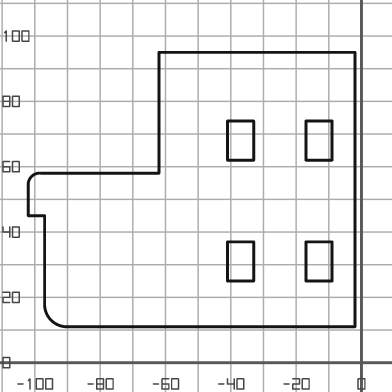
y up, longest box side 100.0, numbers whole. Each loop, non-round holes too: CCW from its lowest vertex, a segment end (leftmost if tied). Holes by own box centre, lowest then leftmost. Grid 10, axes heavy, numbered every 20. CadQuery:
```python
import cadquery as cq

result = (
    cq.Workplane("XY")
    .moveTo(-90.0, 11.0)
    .lineTo(-2.0, 11.0)
    .lineTo(-2.0, 95.0)
    .lineTo(-62.0, 95.0)
    .lineTo(-62.0, 58.0)
    .lineTo(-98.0, 58.0)
    .threePointArc((-101.0, 57.0), (-102.0, 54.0))
    .lineTo(-102.0, 45.0)
    .lineTo(-97.0, 45.0)
    .lineTo(-97.0, 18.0)
    .threePointArc((-95.0, 13.0), (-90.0, 11.0))
    .close()
    .moveTo(-41.0, 25.0)
    .lineTo(-33.0, 25.0)
    .lineTo(-33.0, 37.0)
    .lineTo(-41.0, 37.0)
    .close()
    .moveTo(-17.0, 25.0)
    .lineTo(-9.0, 25.0)
    .lineTo(-9.0, 37.0)
    .lineTo(-17.0, 37.0)
    .close()
    .moveTo(-41.0, 62.0)
    .lineTo(-33.0, 62.0)
    .lineTo(-33.0, 74.0)
    .lineTo(-41.0, 74.0)
    .close()
    .moveTo(-17.0, 62.0)
    .lineTo(-9.0, 62.0)
    .lineTo(-9.0, 74.0)
    .lineTo(-17.0, 74.0)
    .close()
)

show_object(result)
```